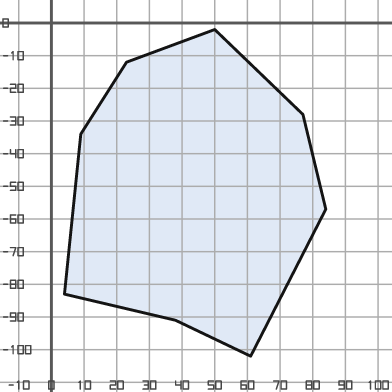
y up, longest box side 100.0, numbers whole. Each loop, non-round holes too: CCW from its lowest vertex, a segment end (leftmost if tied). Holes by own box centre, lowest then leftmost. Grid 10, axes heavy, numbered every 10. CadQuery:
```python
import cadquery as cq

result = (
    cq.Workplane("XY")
    .moveTo(61.0, -102.0)
    .lineTo(84.0, -57.0)
    .lineTo(77.0, -28.0)
    .lineTo(50.0, -2.0)
    .lineTo(23.0, -12.0)
    .lineTo(9.0, -34.0)
    .lineTo(4.0, -83.0)
    .lineTo(38.0, -91.0)
    .close()
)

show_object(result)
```